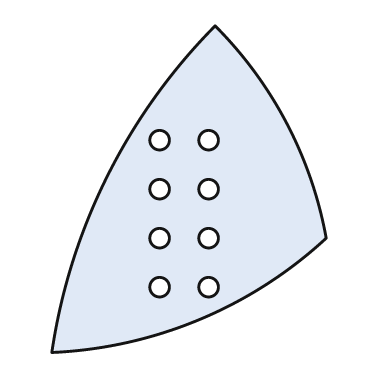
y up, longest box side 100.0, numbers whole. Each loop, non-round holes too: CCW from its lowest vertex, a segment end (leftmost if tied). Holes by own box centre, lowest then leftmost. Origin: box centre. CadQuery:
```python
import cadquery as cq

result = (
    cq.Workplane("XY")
    .moveTo(-42.0, -50.0)
    .threePointArc((3.0, -40.0), (42.0, -15.0))
    .threePointArc((30.0, 20.0), (8.0, 50.0))
    .threePointArc((-25.0, 4.0), (-42.0, -50.0))
    .close()
    .moveTo(-9.0, -30.0)
    .circle(3.0)
    .moveTo(6.0, -30.0)
    .circle(3.0)
    .moveTo(-9.0, -15.0)
    .circle(3.0)
    .moveTo(6.0, -15.0)
    .circle(3.0)
    .moveTo(-9.0, 0.0)
    .circle(3.0)
    .moveTo(6.0, 0.0)
    .circle(3.0)
    .moveTo(-9.0, 15.0)
    .circle(3.0)
    .moveTo(6.0, 15.0)
    .circle(3.0)
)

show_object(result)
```